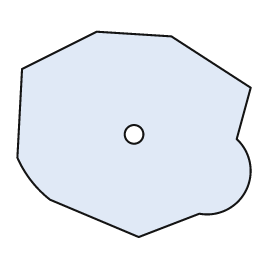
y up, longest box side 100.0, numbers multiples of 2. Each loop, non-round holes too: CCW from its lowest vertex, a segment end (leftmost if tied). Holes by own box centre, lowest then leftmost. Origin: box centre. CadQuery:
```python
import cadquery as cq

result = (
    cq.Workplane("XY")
    .moveTo(2.0, -44.0)
    .lineTo(28.0, -34.0)
    .threePointArc((48.0, -24.0), (44.0, -2.0))
    .lineTo(50.0, 20.0)
    .lineTo(16.0, 42.0)
    .lineTo(-16.0, 44.0)
    .lineTo(-48.0, 28.0)
    .lineTo(-50.0, -10.0)
    .threePointArc((-44.0, -20.0), (-36.0, -28.0))
    .close()
    .moveTo(0.0, 0.0)
    .circle(4.0)
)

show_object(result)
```